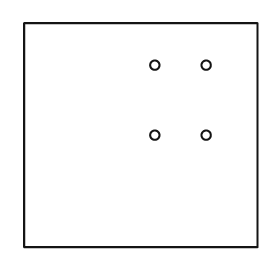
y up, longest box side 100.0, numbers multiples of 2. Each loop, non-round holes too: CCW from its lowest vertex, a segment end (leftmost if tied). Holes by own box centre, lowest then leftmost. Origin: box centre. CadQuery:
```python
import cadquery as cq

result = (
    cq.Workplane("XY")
    .moveTo(-50.0, -48.0)
    .lineTo(50.0, -48.0)
    .lineTo(50.0, 48.0)
    .lineTo(-50.0, 48.0)
    .close()
    .moveTo(6.0, 0.0)
    .circle(2.0)
    .moveTo(28.0, 0.0)
    .circle(2.0)
    .moveTo(6.0, 30.0)
    .circle(2.0)
    .moveTo(28.0, 30.0)
    .circle(2.0)
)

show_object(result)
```